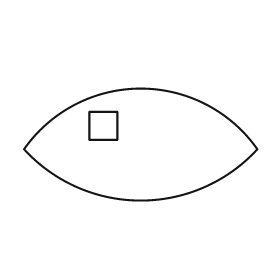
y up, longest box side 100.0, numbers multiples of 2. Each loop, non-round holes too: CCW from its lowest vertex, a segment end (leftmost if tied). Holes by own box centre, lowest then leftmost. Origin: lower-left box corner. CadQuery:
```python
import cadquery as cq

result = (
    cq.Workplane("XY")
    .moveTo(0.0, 22.0)
    .threePointArc((50.0, 0.0), (100.0, 22.0))
    .threePointArc((50.0, 48.0), (0.0, 22.0))
    .close()
    .moveTo(28.0, 26.0)
    .lineTo(40.0, 26.0)
    .lineTo(40.0, 38.0)
    .lineTo(28.0, 38.0)
    .close()
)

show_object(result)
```